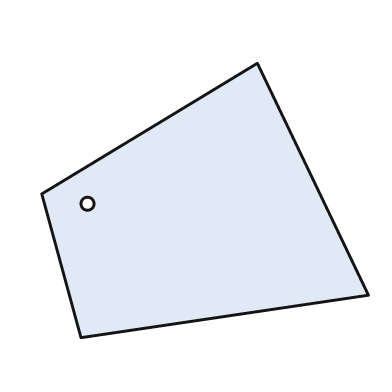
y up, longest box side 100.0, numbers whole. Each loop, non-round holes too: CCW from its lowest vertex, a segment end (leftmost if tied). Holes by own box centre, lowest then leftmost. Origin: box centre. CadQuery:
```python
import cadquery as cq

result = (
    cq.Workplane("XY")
    .moveTo(-38.0, -42.0)
    .lineTo(50.0, -29.0)
    .lineTo(16.0, 42.0)
    .lineTo(-50.0, 2.0)
    .close()
    .moveTo(-36.0, -1.0)
    .circle(2.0)
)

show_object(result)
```